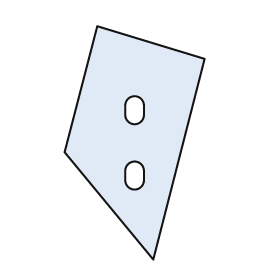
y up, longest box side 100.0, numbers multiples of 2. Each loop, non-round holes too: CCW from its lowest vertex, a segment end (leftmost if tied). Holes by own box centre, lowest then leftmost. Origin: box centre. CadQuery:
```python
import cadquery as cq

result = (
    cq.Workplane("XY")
    .moveTo(8.0, -50.0)
    .lineTo(30.0, 36.0)
    .lineTo(-16.0, 50.0)
    .lineTo(-30.0, -4.0)
    .close()
    .moveTo(-4.0, -16.0)
    .threePointArc((0.0, -20.0), (4.0, -16.0))
    .lineTo(4.0, -12.0)
    .threePointArc((0.0, -8.0), (-4.0, -12.0))
    .close()
    .moveTo(-4.0, 12.0)
    .threePointArc((0.0, 8.0), (4.0, 12.0))
    .lineTo(4.0, 16.0)
    .threePointArc((0.0, 20.0), (-4.0, 16.0))
    .close()
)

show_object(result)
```